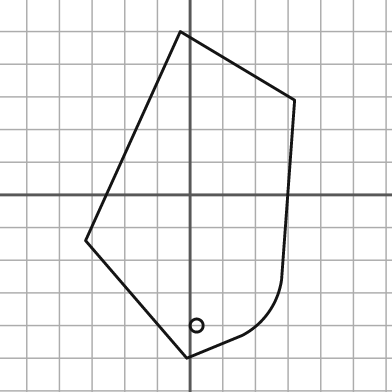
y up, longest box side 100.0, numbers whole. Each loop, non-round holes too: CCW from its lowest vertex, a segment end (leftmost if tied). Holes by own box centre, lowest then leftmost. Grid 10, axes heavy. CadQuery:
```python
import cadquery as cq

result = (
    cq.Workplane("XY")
    .moveTo(-1.0, -50.0)
    .lineTo(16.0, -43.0)
    .threePointArc((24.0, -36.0), (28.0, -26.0))
    .lineTo(32.0, 29.0)
    .lineTo(-3.0, 50.0)
    .lineTo(-32.0, -14.0)
    .close()
    .moveTo(2.0, -40.0)
    .circle(2.0)
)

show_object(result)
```